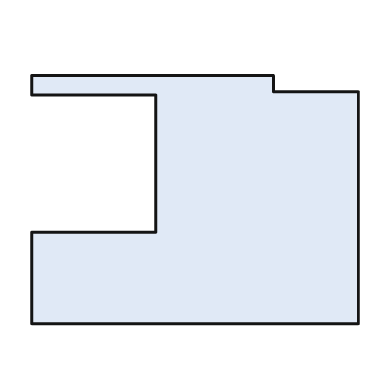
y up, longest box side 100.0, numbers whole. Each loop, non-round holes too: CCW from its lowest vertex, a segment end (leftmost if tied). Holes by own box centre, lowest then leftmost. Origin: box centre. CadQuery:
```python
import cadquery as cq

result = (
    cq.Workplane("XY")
    .moveTo(-50.0, -38.0)
    .lineTo(50.0, -38.0)
    .lineTo(50.0, 33.0)
    .lineTo(24.0, 33.0)
    .lineTo(24.0, 38.0)
    .lineTo(-50.0, 38.0)
    .lineTo(-50.0, 32.0)
    .lineTo(-12.0, 32.0)
    .lineTo(-12.0, -10.0)
    .lineTo(-50.0, -10.0)
    .close()
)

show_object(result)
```